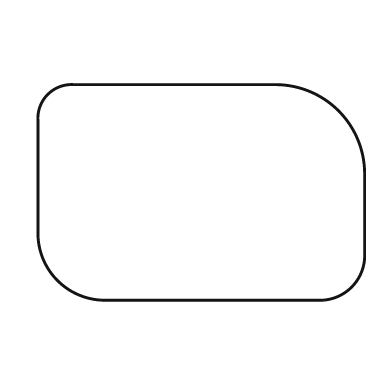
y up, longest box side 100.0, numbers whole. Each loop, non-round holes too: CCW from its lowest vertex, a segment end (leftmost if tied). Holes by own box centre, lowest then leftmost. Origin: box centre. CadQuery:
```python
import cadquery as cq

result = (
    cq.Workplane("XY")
    .moveTo(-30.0, -33.0)
    .lineTo(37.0, -33.0)
    .threePointArc((46.0, -29.0), (50.0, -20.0))
    .lineTo(50.0, 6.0)
    .threePointArc((42.0, 25.0), (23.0, 33.0))
    .lineTo(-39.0, 33.0)
    .threePointArc((-47.0, 30.0), (-50.0, 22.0))
    .lineTo(-50.0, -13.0)
    .threePointArc((-44.0, -27.0), (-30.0, -33.0))
    .close()
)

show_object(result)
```